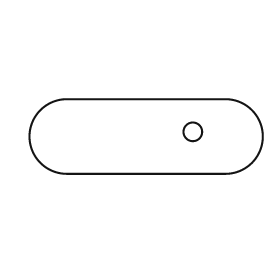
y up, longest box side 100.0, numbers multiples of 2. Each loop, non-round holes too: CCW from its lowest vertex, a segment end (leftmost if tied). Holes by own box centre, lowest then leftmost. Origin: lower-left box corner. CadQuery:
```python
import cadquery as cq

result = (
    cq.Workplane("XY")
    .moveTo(16.0, 0.0)
    .lineTo(84.0, 0.0)
    .threePointArc((100.0, 16.0), (84.0, 32.0))
    .lineTo(16.0, 32.0)
    .threePointArc((0.0, 16.0), (16.0, 0.0))
    .close()
    .moveTo(70.0, 18.0)
    .circle(4.0)
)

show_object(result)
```